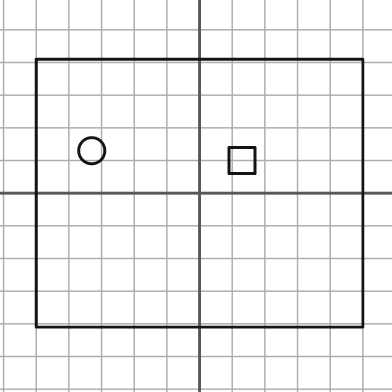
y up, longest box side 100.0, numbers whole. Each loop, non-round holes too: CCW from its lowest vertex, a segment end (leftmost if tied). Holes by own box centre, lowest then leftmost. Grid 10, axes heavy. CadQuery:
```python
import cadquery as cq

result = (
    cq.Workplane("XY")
    .moveTo(-50.0, -41.0)
    .lineTo(50.0, -41.0)
    .lineTo(50.0, 41.0)
    .lineTo(-50.0, 41.0)
    .close()
    .moveTo(9.0, 6.0)
    .lineTo(17.0, 6.0)
    .lineTo(17.0, 14.0)
    .lineTo(9.0, 14.0)
    .close()
    .moveTo(-33.0, 13.0)
    .circle(4.0)
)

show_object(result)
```